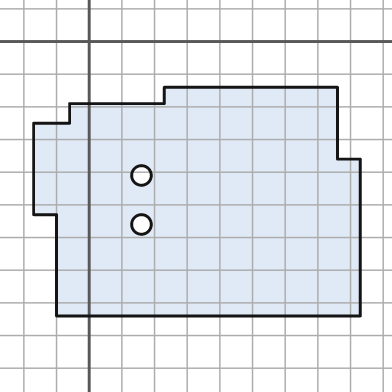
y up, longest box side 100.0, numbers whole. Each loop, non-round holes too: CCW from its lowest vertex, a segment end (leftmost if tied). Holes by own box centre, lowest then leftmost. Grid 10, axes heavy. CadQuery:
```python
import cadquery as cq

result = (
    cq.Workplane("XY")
    .moveTo(-10.0, -84.0)
    .lineTo(83.0, -84.0)
    .lineTo(83.0, -36.0)
    .lineTo(76.0, -36.0)
    .lineTo(76.0, -14.0)
    .lineTo(23.0, -14.0)
    .lineTo(23.0, -19.0)
    .lineTo(-6.0, -19.0)
    .lineTo(-6.0, -25.0)
    .lineTo(-17.0, -25.0)
    .lineTo(-17.0, -53.0)
    .lineTo(-10.0, -53.0)
    .close()
    .moveTo(16.0, -56.0)
    .circle(3.0)
    .moveTo(16.0, -41.0)
    .circle(3.0)
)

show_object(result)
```